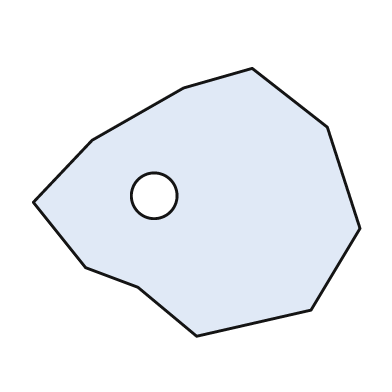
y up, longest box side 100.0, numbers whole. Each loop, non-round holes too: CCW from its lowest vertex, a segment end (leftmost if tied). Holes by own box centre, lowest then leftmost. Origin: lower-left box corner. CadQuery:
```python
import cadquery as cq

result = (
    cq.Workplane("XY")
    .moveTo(50.0, 0.0)
    .lineTo(85.0, 8.0)
    .lineTo(100.0, 33.0)
    .lineTo(90.0, 64.0)
    .lineTo(67.0, 82.0)
    .lineTo(46.0, 76.0)
    .lineTo(18.0, 60.0)
    .lineTo(0.0, 41.0)
    .lineTo(16.0, 21.0)
    .lineTo(32.0, 15.0)
    .close()
    .moveTo(37.0, 43.0)
    .circle(7.0)
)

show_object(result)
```